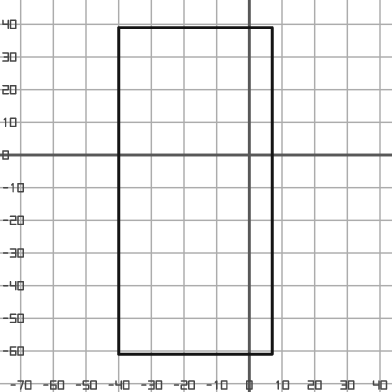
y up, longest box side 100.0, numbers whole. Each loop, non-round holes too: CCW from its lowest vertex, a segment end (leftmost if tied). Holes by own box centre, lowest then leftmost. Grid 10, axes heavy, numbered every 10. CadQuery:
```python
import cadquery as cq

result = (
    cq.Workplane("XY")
    .moveTo(-40.0, -61.0)
    .lineTo(7.0, -61.0)
    .lineTo(7.0, 39.0)
    .lineTo(-40.0, 39.0)
    .close()
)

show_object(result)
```